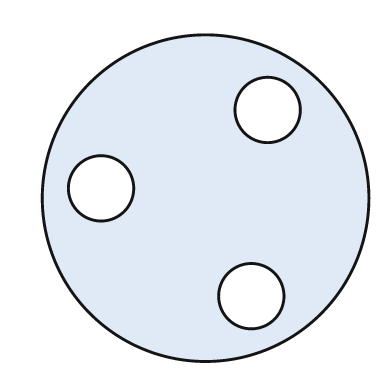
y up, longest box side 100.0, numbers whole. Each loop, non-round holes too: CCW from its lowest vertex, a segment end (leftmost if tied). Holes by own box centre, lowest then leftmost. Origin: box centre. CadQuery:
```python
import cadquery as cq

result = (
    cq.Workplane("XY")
    .moveTo(0.0, 0.0)
    .circle(50.0)
    .moveTo(14.0, -30.0)
    .circle(10.0)
    .moveTo(-32.0, 3.0)
    .circle(10.0)
    .moveTo(19.0, 27.0)
    .circle(10.0)
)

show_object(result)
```